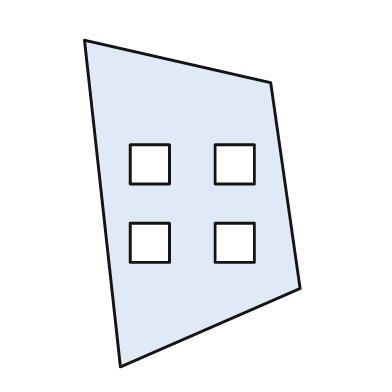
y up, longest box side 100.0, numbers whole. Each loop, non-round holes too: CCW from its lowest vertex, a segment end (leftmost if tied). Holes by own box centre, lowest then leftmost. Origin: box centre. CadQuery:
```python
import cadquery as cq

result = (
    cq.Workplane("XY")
    .moveTo(-22.0, -50.0)
    .lineTo(33.0, -26.0)
    .lineTo(24.0, 37.0)
    .lineTo(-33.0, 50.0)
    .close()
    .moveTo(-19.0, -18.0)
    .lineTo(-7.0, -18.0)
    .lineTo(-7.0, -6.0)
    .lineTo(-19.0, -6.0)
    .close()
    .moveTo(7.0, -18.0)
    .lineTo(19.0, -18.0)
    .lineTo(19.0, -6.0)
    .lineTo(7.0, -6.0)
    .close()
    .moveTo(-19.0, 6.0)
    .lineTo(-7.0, 6.0)
    .lineTo(-7.0, 18.0)
    .lineTo(-19.0, 18.0)
    .close()
    .moveTo(7.0, 6.0)
    .lineTo(19.0, 6.0)
    .lineTo(19.0, 18.0)
    .lineTo(7.0, 18.0)
    .close()
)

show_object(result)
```